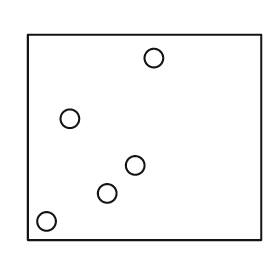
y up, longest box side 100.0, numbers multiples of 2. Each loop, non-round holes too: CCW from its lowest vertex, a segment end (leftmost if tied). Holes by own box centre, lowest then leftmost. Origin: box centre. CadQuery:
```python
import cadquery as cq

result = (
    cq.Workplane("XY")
    .moveTo(-50.0, -44.0)
    .lineTo(50.0, -44.0)
    .lineTo(50.0, 44.0)
    .lineTo(-50.0, 44.0)
    .close()
    .moveTo(-42.0, -36.0)
    .circle(4.0)
    .moveTo(-16.0, -24.0)
    .circle(4.0)
    .moveTo(-4.0, -12.0)
    .circle(4.0)
    .moveTo(-32.0, 8.0)
    .circle(4.0)
    .moveTo(4.0, 34.0)
    .circle(4.0)
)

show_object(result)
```